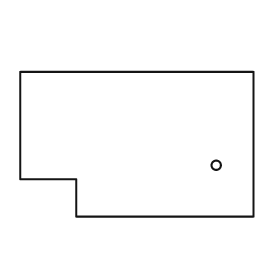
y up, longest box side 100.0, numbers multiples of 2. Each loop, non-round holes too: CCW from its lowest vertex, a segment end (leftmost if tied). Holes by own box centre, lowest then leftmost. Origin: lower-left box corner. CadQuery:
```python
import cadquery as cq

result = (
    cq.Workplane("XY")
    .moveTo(24.0, 0.0)
    .lineTo(100.0, 0.0)
    .lineTo(100.0, 62.0)
    .lineTo(0.0, 62.0)
    .lineTo(0.0, 16.0)
    .lineTo(24.0, 16.0)
    .close()
    .moveTo(84.0, 22.0)
    .circle(2.0)
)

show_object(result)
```